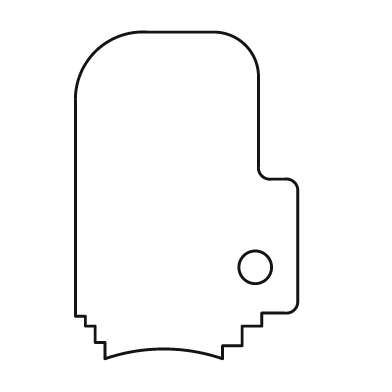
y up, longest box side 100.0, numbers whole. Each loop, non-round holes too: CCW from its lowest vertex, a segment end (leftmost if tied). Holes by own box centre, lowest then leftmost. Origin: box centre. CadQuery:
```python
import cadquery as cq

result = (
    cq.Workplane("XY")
    .moveTo(-25.0, -50.0)
    .threePointArc((-7.0, -47.0), (11.0, -50.0))
    .lineTo(11.0, -46.0)
    .lineTo(17.0, -46.0)
    .lineTo(17.0, -40.0)
    .lineTo(23.0, -40.0)
    .lineTo(23.0, -36.0)
    .lineTo(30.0, -36.0)
    .threePointArc((33.0, -35.0), (34.0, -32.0))
    .lineTo(34.0, 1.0)
    .threePointArc((33.0, 4.0), (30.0, 5.0))
    .lineTo(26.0, 5.0)
    .threePointArc((23.0, 6.0), (22.0, 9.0))
    .lineTo(22.0, 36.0)
    .threePointArc((18.0, 46.0), (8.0, 50.0))
    .lineTo(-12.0, 50.0)
    .threePointArc((-28.0, 44.0), (-34.0, 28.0))
    .lineTo(-34.0, -37.0)
    .lineTo(-31.0, -37.0)
    .lineTo(-31.0, -40.0)
    .lineTo(-28.0, -40.0)
    .lineTo(-28.0, -45.0)
    .lineTo(-25.0, -45.0)
    .close()
    .moveTo(21.0, -22.0)
    .circle(5.0)
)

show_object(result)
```